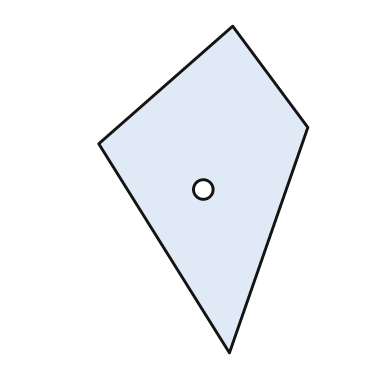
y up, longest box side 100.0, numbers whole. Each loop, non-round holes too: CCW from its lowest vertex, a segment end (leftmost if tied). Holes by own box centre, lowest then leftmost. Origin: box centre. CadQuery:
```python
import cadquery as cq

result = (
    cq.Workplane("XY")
    .moveTo(8.0, -50.0)
    .lineTo(32.0, 19.0)
    .lineTo(9.0, 50.0)
    .lineTo(-32.0, 14.0)
    .close()
    .moveTo(0.0, 0.0)
    .circle(3.0)
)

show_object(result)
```